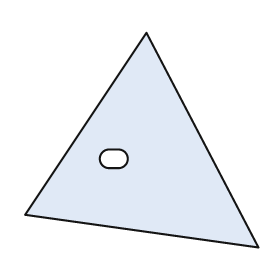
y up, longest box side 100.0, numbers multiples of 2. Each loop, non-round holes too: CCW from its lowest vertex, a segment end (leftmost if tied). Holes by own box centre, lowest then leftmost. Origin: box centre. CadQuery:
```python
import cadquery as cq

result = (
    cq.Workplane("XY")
    .moveTo(50.0, -46.0)
    .lineTo(2.0, 46.0)
    .lineTo(-50.0, -32.0)
    .close()
    .moveTo(-14.0, -12.0)
    .lineTo(-10.0, -12.0)
    .threePointArc((-6.0, -8.0), (-10.0, -4.0))
    .lineTo(-14.0, -4.0)
    .threePointArc((-18.0, -8.0), (-14.0, -12.0))
    .close()
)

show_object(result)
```